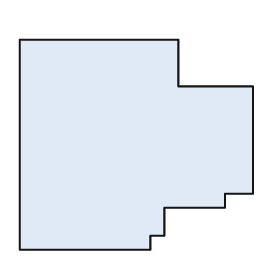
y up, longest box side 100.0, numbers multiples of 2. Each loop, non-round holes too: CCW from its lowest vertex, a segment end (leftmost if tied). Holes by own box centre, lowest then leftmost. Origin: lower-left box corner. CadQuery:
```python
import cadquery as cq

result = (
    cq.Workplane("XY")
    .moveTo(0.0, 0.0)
    .lineTo(56.0, 0.0)
    .lineTo(56.0, 6.0)
    .lineTo(62.0, 6.0)
    .lineTo(62.0, 18.0)
    .lineTo(88.0, 18.0)
    .lineTo(88.0, 24.0)
    .lineTo(100.0, 24.0)
    .lineTo(100.0, 70.0)
    .lineTo(68.0, 70.0)
    .lineTo(68.0, 90.0)
    .lineTo(0.0, 90.0)
    .close()
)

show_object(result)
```